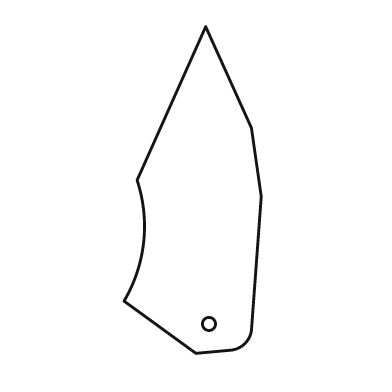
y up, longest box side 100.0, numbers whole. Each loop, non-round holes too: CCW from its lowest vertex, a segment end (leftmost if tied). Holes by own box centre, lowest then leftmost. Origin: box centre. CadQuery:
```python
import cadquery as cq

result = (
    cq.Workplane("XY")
    .moveTo(1.0, -50.0)
    .lineTo(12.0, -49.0)
    .threePointArc((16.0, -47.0), (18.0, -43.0))
    .lineTo(21.0, -2.0)
    .lineTo(18.0, 19.0)
    .lineTo(4.0, 50.0)
    .lineTo(-17.0, 3.0)
    .threePointArc((-15.0, -16.0), (-21.0, -34.0))
    .close()
    .moveTo(5.0, -41.0)
    .circle(2.0)
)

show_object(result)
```